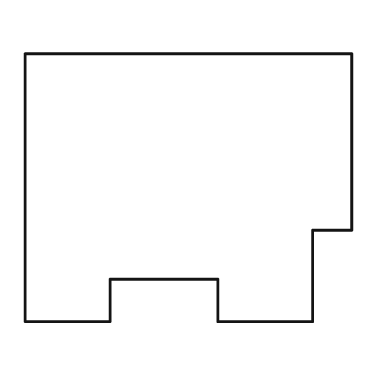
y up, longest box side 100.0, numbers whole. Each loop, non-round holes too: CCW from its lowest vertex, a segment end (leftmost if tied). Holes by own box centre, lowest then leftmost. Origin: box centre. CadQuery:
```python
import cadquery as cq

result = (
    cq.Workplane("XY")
    .moveTo(-50.0, -41.0)
    .lineTo(-24.0, -41.0)
    .lineTo(-24.0, -28.0)
    .lineTo(9.0, -28.0)
    .lineTo(9.0, -41.0)
    .lineTo(38.0, -41.0)
    .lineTo(38.0, -13.0)
    .lineTo(50.0, -13.0)
    .lineTo(50.0, 41.0)
    .lineTo(-50.0, 41.0)
    .close()
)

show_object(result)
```